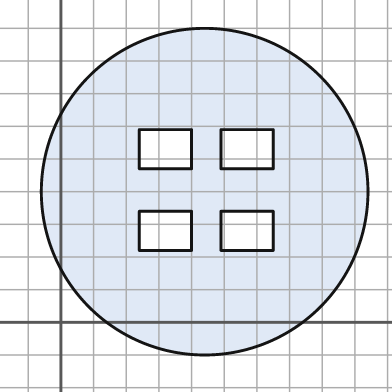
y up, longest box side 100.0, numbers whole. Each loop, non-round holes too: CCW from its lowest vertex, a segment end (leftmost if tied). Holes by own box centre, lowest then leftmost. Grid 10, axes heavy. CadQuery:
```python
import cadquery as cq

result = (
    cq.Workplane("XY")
    .moveTo(44.0, 40.0)
    .circle(50.0)
    .moveTo(24.0, 22.0)
    .lineTo(40.0, 22.0)
    .lineTo(40.0, 34.0)
    .lineTo(24.0, 34.0)
    .close()
    .moveTo(49.0, 22.0)
    .lineTo(65.0, 22.0)
    .lineTo(65.0, 34.0)
    .lineTo(49.0, 34.0)
    .close()
    .moveTo(24.0, 47.0)
    .lineTo(40.0, 47.0)
    .lineTo(40.0, 59.0)
    .lineTo(24.0, 59.0)
    .close()
    .moveTo(49.0, 47.0)
    .lineTo(65.0, 47.0)
    .lineTo(65.0, 59.0)
    .lineTo(49.0, 59.0)
    .close()
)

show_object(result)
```